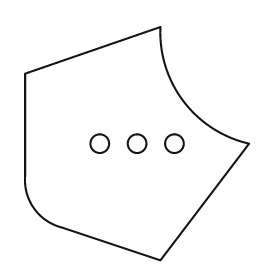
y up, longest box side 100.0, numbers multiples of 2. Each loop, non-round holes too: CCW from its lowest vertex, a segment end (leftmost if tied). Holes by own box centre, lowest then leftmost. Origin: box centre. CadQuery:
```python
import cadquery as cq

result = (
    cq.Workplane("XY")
    .moveTo(10.0, -50.0)
    .lineTo(48.0, 0.0)
    .threePointArc((20.0, 18.0), (10.0, 50.0))
    .lineTo(-48.0, 30.0)
    .lineTo(-48.0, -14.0)
    .threePointArc((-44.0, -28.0), (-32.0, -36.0))
    .close()
    .moveTo(-16.0, 0.0)
    .circle(4.0)
    .moveTo(0.0, 0.0)
    .circle(4.0)
    .moveTo(16.0, 0.0)
    .circle(4.0)
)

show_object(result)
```